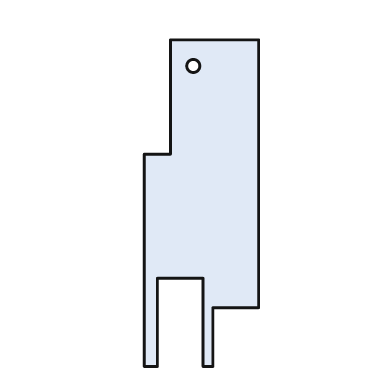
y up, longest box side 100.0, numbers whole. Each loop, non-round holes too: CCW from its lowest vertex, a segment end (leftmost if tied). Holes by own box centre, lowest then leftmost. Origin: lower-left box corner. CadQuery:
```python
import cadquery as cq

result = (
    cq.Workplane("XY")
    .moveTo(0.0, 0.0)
    .lineTo(4.0, 0.0)
    .lineTo(4.0, 27.0)
    .lineTo(18.0, 27.0)
    .lineTo(18.0, 0.0)
    .lineTo(21.0, 0.0)
    .lineTo(21.0, 18.0)
    .lineTo(35.0, 18.0)
    .lineTo(35.0, 100.0)
    .lineTo(8.0, 100.0)
    .lineTo(8.0, 65.0)
    .lineTo(0.0, 65.0)
    .close()
    .moveTo(15.0, 92.0)
    .circle(2.0)
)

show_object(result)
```